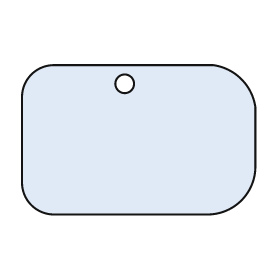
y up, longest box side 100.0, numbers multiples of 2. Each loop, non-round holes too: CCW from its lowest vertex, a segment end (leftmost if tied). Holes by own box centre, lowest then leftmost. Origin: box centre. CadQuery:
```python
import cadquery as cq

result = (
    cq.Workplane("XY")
    .moveTo(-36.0, -32.0)
    .lineTo(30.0, -32.0)
    .threePointArc((44.0, -26.0), (50.0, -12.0))
    .lineTo(50.0, 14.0)
    .threePointArc((44.0, 26.0), (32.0, 32.0))
    .lineTo(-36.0, 32.0)
    .threePointArc((-46.0, 28.0), (-50.0, 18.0))
    .lineTo(-50.0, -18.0)
    .threePointArc((-46.0, -28.0), (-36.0, -32.0))
    .close()
    .moveTo(-6.0, 24.0)
    .circle(4.0)
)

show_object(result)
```